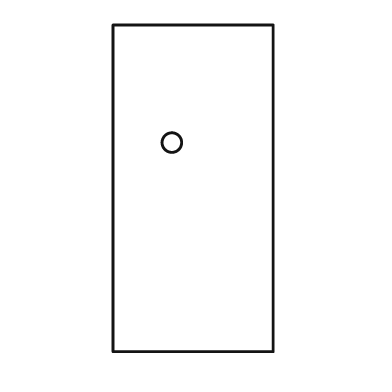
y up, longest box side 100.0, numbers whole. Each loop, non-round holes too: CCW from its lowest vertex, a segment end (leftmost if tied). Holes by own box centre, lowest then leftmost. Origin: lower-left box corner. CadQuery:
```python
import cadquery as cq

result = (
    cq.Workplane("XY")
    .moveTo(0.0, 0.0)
    .lineTo(49.0, 0.0)
    .lineTo(49.0, 100.0)
    .lineTo(0.0, 100.0)
    .close()
    .moveTo(18.0, 64.0)
    .circle(3.0)
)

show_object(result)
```